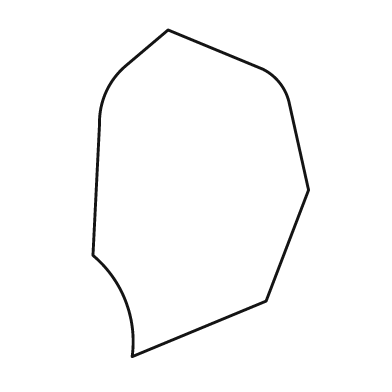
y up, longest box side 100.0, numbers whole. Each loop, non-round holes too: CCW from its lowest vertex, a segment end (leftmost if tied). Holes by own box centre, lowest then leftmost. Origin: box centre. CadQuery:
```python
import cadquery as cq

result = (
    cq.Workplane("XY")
    .moveTo(-21.0, -50.0)
    .lineTo(20.0, -33.0)
    .lineTo(33.0, 1.0)
    .lineTo(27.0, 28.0)
    .threePointArc((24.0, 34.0), (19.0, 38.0))
    .lineTo(-10.0, 50.0)
    .lineTo(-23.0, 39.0)
    .threePointArc((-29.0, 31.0), (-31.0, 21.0))
    .lineTo(-33.0, -19.0)
    .threePointArc((-23.0, -33.0), (-21.0, -50.0))
    .close()
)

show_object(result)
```